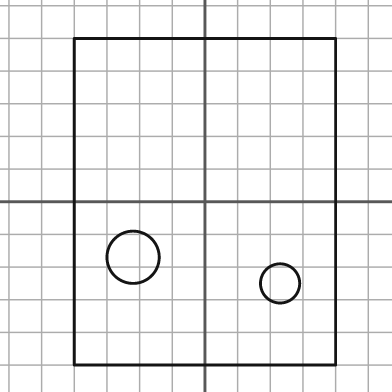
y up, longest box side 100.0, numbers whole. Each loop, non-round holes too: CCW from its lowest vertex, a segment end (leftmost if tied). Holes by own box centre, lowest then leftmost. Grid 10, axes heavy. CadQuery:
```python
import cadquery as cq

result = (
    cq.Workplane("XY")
    .moveTo(-40.0, -50.0)
    .lineTo(40.0, -50.0)
    .lineTo(40.0, 50.0)
    .lineTo(-40.0, 50.0)
    .close()
    .moveTo(23.0, -25.0)
    .circle(6.0)
    .moveTo(-22.0, -17.0)
    .circle(8.0)
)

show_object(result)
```